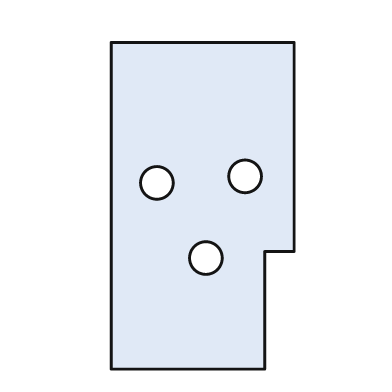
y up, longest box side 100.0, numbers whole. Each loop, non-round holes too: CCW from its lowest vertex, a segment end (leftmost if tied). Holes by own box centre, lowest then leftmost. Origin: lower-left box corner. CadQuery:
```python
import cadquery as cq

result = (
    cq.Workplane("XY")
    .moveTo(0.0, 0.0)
    .lineTo(47.0, 0.0)
    .lineTo(47.0, 36.0)
    .lineTo(56.0, 36.0)
    .lineTo(56.0, 100.0)
    .lineTo(0.0, 100.0)
    .close()
    .moveTo(29.0, 34.0)
    .circle(5.0)
    .moveTo(14.0, 57.0)
    .circle(5.0)
    .moveTo(41.0, 59.0)
    .circle(5.0)
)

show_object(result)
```